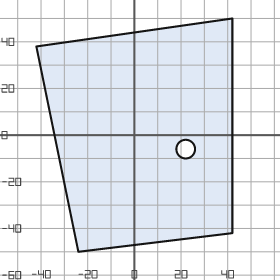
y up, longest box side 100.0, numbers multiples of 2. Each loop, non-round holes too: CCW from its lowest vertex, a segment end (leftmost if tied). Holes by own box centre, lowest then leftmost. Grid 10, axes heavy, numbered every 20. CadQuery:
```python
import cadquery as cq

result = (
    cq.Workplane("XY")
    .moveTo(-24.0, -50.0)
    .lineTo(42.0, -42.0)
    .lineTo(42.0, 50.0)
    .lineTo(-42.0, 38.0)
    .close()
    .moveTo(22.0, -6.0)
    .circle(4.0)
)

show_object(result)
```